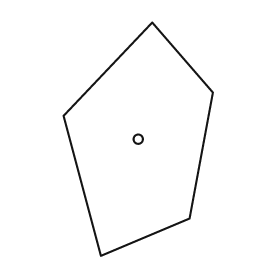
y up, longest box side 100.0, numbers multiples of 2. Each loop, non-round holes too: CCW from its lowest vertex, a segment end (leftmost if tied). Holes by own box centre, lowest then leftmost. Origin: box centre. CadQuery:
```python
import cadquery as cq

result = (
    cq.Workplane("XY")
    .moveTo(-16.0, -50.0)
    .lineTo(22.0, -34.0)
    .lineTo(32.0, 20.0)
    .lineTo(6.0, 50.0)
    .lineTo(-32.0, 10.0)
    .close()
    .moveTo(0.0, 0.0)
    .circle(2.0)
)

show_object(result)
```